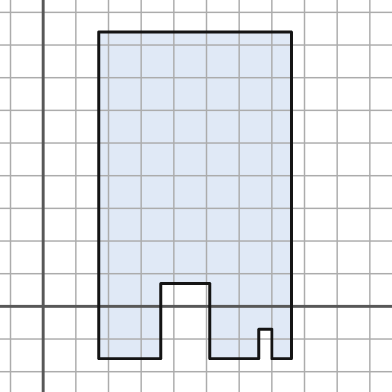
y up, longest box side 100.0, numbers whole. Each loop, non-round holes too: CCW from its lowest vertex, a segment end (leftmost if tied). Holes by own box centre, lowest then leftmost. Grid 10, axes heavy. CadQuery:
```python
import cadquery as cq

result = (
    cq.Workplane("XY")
    .moveTo(17.0, -16.0)
    .lineTo(36.0, -16.0)
    .lineTo(36.0, 7.0)
    .lineTo(51.0, 7.0)
    .lineTo(51.0, -16.0)
    .lineTo(66.0, -16.0)
    .lineTo(66.0, -7.0)
    .lineTo(70.0, -7.0)
    .lineTo(70.0, -16.0)
    .lineTo(76.0, -16.0)
    .lineTo(76.0, 84.0)
    .lineTo(17.0, 84.0)
    .close()
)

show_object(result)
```